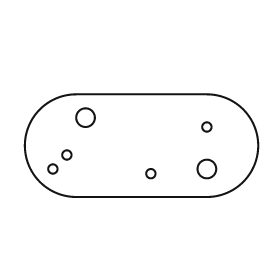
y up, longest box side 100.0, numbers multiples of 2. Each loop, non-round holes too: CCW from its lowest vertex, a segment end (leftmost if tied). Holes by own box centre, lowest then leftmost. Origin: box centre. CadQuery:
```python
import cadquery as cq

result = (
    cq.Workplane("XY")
    .moveTo(-28.0, -22.0)
    .lineTo(28.0, -22.0)
    .threePointArc((50.0, 0.0), (28.0, 22.0))
    .lineTo(-28.0, 22.0)
    .threePointArc((-50.0, 0.0), (-28.0, -22.0))
    .close()
    .moveTo(4.0, -12.0)
    .circle(2.0)
    .moveTo(-38.0, -10.0)
    .circle(2.0)
    .moveTo(28.0, -10.0)
    .circle(4.0)
    .moveTo(-32.0, -4.0)
    .circle(2.0)
    .moveTo(28.0, 8.0)
    .circle(2.0)
    .moveTo(-24.0, 12.0)
    .circle(4.0)
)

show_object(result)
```